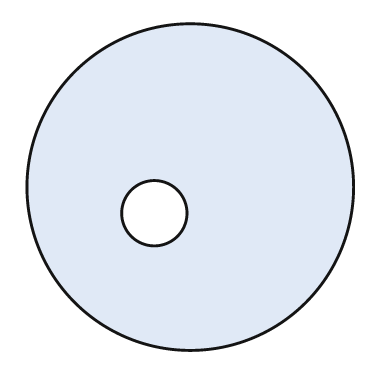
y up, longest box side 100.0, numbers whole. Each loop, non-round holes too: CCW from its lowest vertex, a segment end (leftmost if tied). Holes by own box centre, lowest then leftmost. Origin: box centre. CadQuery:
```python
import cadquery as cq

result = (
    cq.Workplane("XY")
    .moveTo(0.0, 0.0)
    .circle(50.0)
    .moveTo(-11.0, -8.0)
    .circle(10.0)
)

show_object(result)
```